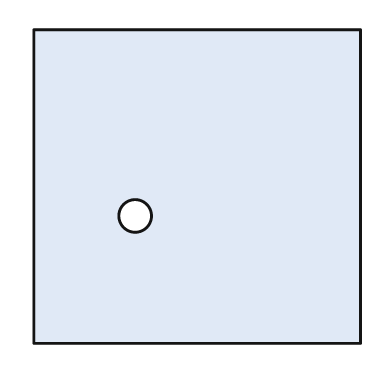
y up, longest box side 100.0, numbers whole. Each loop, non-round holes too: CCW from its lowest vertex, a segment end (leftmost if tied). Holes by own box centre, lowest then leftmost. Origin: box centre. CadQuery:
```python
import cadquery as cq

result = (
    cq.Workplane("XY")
    .moveTo(-50.0, -48.0)
    .lineTo(50.0, -48.0)
    .lineTo(50.0, 48.0)
    .lineTo(-50.0, 48.0)
    .close()
    .moveTo(-19.0, -9.0)
    .circle(5.0)
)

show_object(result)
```